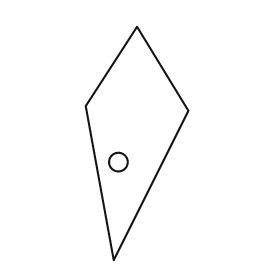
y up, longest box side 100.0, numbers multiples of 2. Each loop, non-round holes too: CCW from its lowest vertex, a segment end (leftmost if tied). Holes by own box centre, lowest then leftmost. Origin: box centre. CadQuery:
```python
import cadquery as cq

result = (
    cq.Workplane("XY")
    .moveTo(-10.0, -50.0)
    .lineTo(22.0, 14.0)
    .lineTo(0.0, 50.0)
    .lineTo(-22.0, 16.0)
    .close()
    .moveTo(-8.0, -8.0)
    .circle(4.0)
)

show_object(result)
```